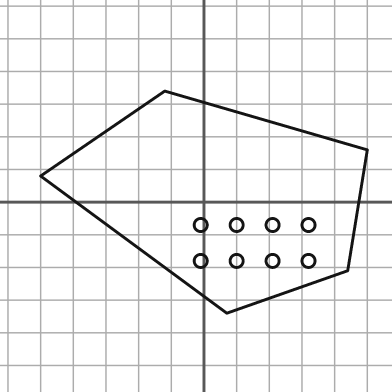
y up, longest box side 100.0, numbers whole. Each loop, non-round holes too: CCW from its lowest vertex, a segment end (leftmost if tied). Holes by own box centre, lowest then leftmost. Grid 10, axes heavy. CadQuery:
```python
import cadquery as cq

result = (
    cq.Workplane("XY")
    .moveTo(7.0, -34.0)
    .lineTo(44.0, -21.0)
    .lineTo(50.0, 16.0)
    .lineTo(-12.0, 34.0)
    .lineTo(-50.0, 8.0)
    .close()
    .moveTo(-1.0, -18.0)
    .circle(2.0)
    .moveTo(10.0, -18.0)
    .circle(2.0)
    .moveTo(21.0, -18.0)
    .circle(2.0)
    .moveTo(32.0, -18.0)
    .circle(2.0)
    .moveTo(-1.0, -7.0)
    .circle(2.0)
    .moveTo(10.0, -7.0)
    .circle(2.0)
    .moveTo(21.0, -7.0)
    .circle(2.0)
    .moveTo(32.0, -7.0)
    .circle(2.0)
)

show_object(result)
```